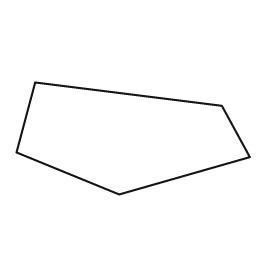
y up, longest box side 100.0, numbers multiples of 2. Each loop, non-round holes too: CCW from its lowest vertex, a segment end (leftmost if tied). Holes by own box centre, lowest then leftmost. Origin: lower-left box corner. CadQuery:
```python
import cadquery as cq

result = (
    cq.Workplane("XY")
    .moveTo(44.0, 0.0)
    .lineTo(100.0, 16.0)
    .lineTo(88.0, 38.0)
    .lineTo(8.0, 48.0)
    .lineTo(0.0, 18.0)
    .close()
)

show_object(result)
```